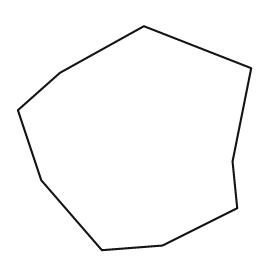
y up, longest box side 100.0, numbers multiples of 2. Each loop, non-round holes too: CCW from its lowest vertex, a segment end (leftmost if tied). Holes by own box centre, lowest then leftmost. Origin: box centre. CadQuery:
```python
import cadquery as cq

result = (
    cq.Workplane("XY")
    .moveTo(-14.0, -48.0)
    .lineTo(12.0, -46.0)
    .lineTo(44.0, -30.0)
    .lineTo(42.0, -10.0)
    .lineTo(50.0, 30.0)
    .lineTo(4.0, 48.0)
    .lineTo(-32.0, 28.0)
    .lineTo(-50.0, 12.0)
    .lineTo(-40.0, -18.0)
    .close()
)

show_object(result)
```